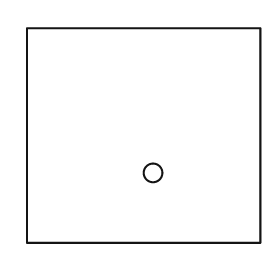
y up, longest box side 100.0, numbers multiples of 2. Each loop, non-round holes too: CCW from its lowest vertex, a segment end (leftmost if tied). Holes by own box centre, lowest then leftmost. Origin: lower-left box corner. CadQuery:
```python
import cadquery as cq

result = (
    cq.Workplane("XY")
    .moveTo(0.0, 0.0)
    .lineTo(100.0, 0.0)
    .lineTo(100.0, 92.0)
    .lineTo(0.0, 92.0)
    .close()
    .moveTo(54.0, 30.0)
    .circle(4.0)
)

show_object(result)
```